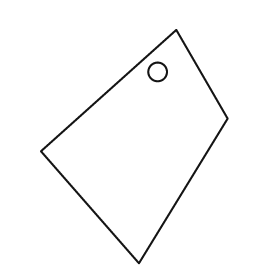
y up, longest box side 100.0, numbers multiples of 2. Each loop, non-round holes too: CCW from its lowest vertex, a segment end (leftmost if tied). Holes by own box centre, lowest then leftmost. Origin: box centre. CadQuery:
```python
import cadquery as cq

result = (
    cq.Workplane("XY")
    .moveTo(2.0, -50.0)
    .lineTo(40.0, 12.0)
    .lineTo(18.0, 50.0)
    .lineTo(-40.0, -2.0)
    .close()
    .moveTo(10.0, 32.0)
    .circle(4.0)
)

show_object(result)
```